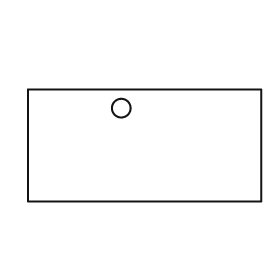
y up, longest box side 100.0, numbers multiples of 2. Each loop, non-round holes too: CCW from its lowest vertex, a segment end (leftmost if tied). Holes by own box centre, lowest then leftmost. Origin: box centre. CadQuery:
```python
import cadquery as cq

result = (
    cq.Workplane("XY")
    .moveTo(-50.0, -24.0)
    .lineTo(50.0, -24.0)
    .lineTo(50.0, 24.0)
    .lineTo(-50.0, 24.0)
    .close()
    .moveTo(-10.0, 16.0)
    .circle(4.0)
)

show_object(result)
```